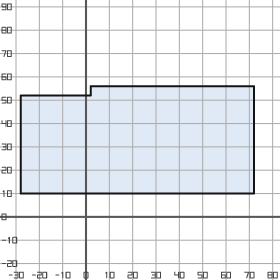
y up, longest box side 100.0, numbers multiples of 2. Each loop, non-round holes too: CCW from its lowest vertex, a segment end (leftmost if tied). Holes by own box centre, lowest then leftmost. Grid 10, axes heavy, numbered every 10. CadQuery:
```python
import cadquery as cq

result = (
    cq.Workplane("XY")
    .moveTo(-28.0, 10.0)
    .lineTo(72.0, 10.0)
    .lineTo(72.0, 56.0)
    .lineTo(2.0, 56.0)
    .lineTo(2.0, 52.0)
    .lineTo(-28.0, 52.0)
    .close()
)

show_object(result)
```